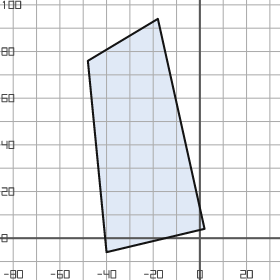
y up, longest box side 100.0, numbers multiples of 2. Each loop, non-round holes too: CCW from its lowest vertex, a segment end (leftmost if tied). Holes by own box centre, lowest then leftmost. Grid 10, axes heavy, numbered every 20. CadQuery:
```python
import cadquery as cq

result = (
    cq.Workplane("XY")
    .moveTo(-40.0, -6.0)
    .lineTo(2.0, 4.0)
    .lineTo(-18.0, 94.0)
    .lineTo(-48.0, 76.0)
    .close()
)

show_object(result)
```